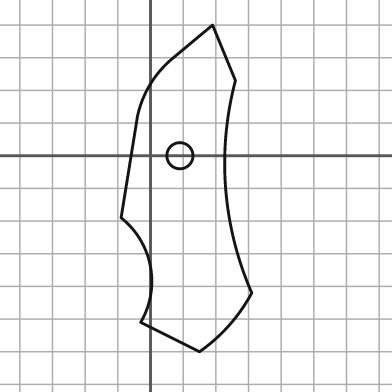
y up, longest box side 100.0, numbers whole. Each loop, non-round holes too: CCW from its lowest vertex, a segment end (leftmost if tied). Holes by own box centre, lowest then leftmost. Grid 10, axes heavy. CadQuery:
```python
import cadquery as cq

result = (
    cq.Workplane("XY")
    .moveTo(15.0, -60.0)
    .threePointArc((24.0, -52.0), (31.0, -42.0))
    .threePointArc((23.0, -10.0), (26.0, 23.0))
    .lineTo(19.0, 40.0)
    .lineTo(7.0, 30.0)
    .threePointArc((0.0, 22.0), (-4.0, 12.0))
    .lineTo(-9.0, -19.0)
    .threePointArc((0.0, -34.0), (-3.0, -51.0))
    .close()
    .moveTo(9.0, 0.0)
    .circle(4.0)
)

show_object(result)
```